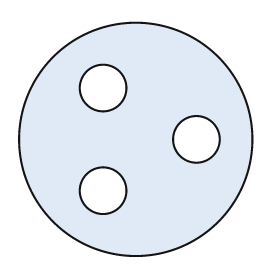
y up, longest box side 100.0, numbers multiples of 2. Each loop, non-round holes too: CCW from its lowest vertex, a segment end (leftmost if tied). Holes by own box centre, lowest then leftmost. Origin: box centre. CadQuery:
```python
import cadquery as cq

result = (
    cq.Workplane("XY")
    .moveTo(0.0, 0.0)
    .circle(50.0)
    .moveTo(-14.0, -22.0)
    .circle(10.0)
    .moveTo(26.0, 0.0)
    .circle(10.0)
    .moveTo(-14.0, 22.0)
    .circle(10.0)
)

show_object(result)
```